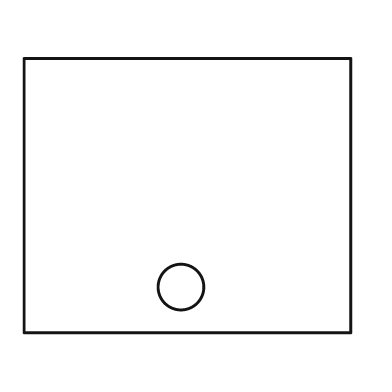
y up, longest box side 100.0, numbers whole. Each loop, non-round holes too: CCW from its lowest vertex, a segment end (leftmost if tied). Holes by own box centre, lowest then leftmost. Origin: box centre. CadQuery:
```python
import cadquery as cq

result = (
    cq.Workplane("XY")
    .moveTo(-50.0, -42.0)
    .lineTo(50.0, -42.0)
    .lineTo(50.0, 42.0)
    .lineTo(-50.0, 42.0)
    .close()
    .moveTo(-2.0, -28.0)
    .circle(7.0)
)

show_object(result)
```